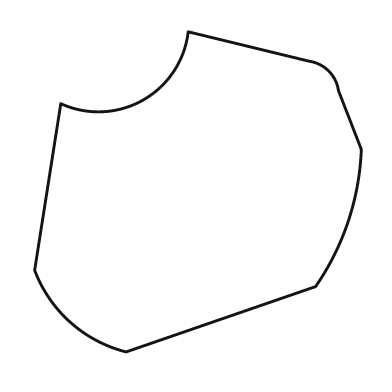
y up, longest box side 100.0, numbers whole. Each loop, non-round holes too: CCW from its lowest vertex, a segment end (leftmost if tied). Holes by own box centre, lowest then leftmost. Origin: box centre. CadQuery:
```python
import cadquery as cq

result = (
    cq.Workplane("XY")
    .moveTo(-22.0, -49.0)
    .lineTo(36.0, -29.0)
    .threePointArc((46.0, -9.0), (50.0, 13.0))
    .lineTo(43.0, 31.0)
    .threePointArc((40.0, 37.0), (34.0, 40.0))
    .lineTo(-3.0, 49.0)
    .threePointArc((-17.0, 28.0), (-42.0, 27.0))
    .lineTo(-50.0, -24.0)
    .threePointArc((-39.0, -40.0), (-22.0, -49.0))
    .close()
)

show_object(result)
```